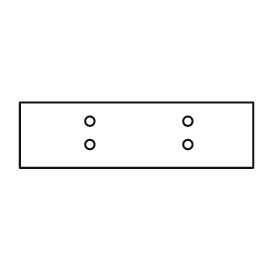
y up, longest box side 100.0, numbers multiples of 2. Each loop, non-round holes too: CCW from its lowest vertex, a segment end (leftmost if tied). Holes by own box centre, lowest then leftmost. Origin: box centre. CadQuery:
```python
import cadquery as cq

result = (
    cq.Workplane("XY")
    .moveTo(-50.0, -14.0)
    .lineTo(50.0, -14.0)
    .lineTo(50.0, 14.0)
    .lineTo(-50.0, 14.0)
    .close()
    .moveTo(-20.0, -4.0)
    .circle(2.0)
    .moveTo(22.0, -4.0)
    .circle(2.0)
    .moveTo(-20.0, 6.0)
    .circle(2.0)
    .moveTo(22.0, 6.0)
    .circle(2.0)
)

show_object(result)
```